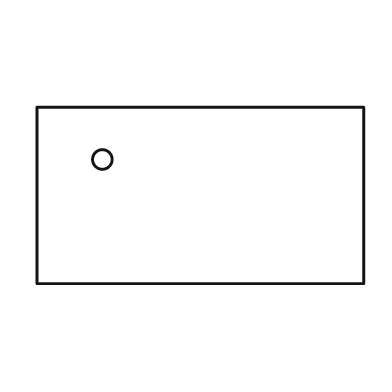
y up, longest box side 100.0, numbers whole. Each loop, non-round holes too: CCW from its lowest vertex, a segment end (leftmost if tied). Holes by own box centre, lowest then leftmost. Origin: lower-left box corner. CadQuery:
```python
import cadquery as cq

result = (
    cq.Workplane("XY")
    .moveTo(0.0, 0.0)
    .lineTo(100.0, 0.0)
    .lineTo(100.0, 54.0)
    .lineTo(0.0, 54.0)
    .close()
    .moveTo(20.0, 38.0)
    .circle(3.0)
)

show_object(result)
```